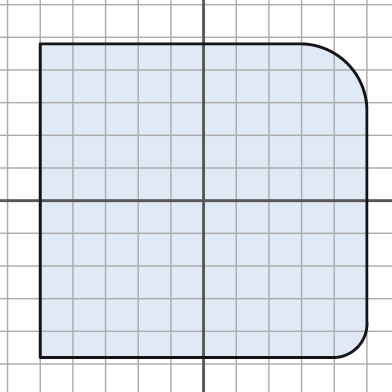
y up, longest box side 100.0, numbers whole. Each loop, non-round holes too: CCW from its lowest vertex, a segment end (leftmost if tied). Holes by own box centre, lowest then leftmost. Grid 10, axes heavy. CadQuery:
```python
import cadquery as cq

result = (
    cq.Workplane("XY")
    .moveTo(-50.0, -48.0)
    .lineTo(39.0, -48.0)
    .threePointArc((47.0, -45.0), (50.0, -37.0))
    .lineTo(50.0, 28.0)
    .threePointArc((44.0, 42.0), (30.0, 48.0))
    .lineTo(-50.0, 48.0)
    .close()
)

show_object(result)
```